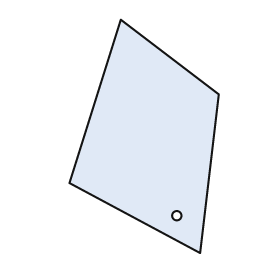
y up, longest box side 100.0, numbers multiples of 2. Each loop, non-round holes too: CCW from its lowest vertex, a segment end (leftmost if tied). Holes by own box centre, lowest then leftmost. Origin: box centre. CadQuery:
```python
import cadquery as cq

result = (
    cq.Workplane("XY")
    .moveTo(24.0, -50.0)
    .lineTo(32.0, 18.0)
    .lineTo(-10.0, 50.0)
    .lineTo(-32.0, -20.0)
    .close()
    .moveTo(14.0, -34.0)
    .circle(2.0)
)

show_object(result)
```